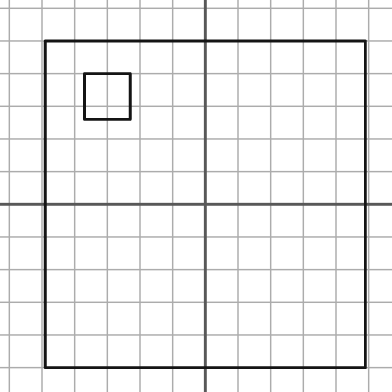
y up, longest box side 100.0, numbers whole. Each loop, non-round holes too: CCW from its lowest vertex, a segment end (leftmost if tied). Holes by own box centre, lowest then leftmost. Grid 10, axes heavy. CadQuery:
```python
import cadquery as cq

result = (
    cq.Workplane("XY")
    .moveTo(-49.0, -50.0)
    .lineTo(49.0, -50.0)
    .lineTo(49.0, 50.0)
    .lineTo(-49.0, 50.0)
    .close()
    .moveTo(-37.0, 26.0)
    .lineTo(-23.0, 26.0)
    .lineTo(-23.0, 40.0)
    .lineTo(-37.0, 40.0)
    .close()
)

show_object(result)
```